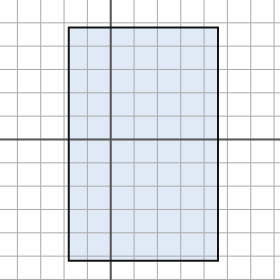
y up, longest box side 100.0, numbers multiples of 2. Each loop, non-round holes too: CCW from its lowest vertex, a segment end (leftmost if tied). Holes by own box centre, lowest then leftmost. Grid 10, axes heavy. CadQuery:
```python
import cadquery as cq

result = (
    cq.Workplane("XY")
    .moveTo(-18.0, -52.0)
    .lineTo(46.0, -52.0)
    .lineTo(46.0, 48.0)
    .lineTo(-18.0, 48.0)
    .close()
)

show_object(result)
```